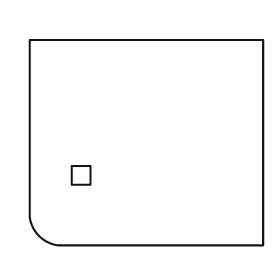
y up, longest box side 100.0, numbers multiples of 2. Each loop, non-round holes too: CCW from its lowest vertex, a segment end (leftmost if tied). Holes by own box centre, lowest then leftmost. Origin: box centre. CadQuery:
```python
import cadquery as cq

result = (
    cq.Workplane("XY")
    .moveTo(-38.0, -44.0)
    .lineTo(50.0, -44.0)
    .lineTo(50.0, 44.0)
    .lineTo(-50.0, 44.0)
    .lineTo(-50.0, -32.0)
    .threePointArc((-46.0, -40.0), (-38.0, -44.0))
    .close()
    .moveTo(-32.0, -18.0)
    .lineTo(-24.0, -18.0)
    .lineTo(-24.0, -10.0)
    .lineTo(-32.0, -10.0)
    .close()
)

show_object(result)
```